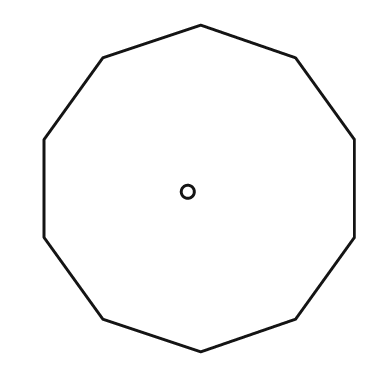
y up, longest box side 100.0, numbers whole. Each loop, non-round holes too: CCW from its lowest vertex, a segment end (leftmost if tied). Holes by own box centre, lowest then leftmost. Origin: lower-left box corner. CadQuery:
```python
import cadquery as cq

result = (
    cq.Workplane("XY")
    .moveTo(48.0, 0.0)
    .lineTo(77.0, 10.0)
    .lineTo(95.0, 35.0)
    .lineTo(95.0, 65.0)
    .lineTo(77.0, 90.0)
    .lineTo(48.0, 100.0)
    .lineTo(18.0, 90.0)
    .lineTo(0.0, 65.0)
    .lineTo(0.0, 35.0)
    .lineTo(18.0, 10.0)
    .close()
    .moveTo(44.0, 49.0)
    .circle(2.0)
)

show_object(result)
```